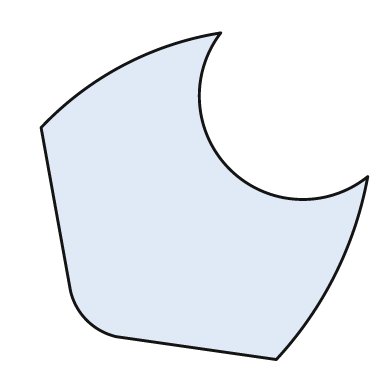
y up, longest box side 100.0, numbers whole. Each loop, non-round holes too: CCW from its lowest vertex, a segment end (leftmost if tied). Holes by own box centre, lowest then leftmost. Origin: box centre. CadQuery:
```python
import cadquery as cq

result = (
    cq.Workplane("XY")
    .moveTo(22.0, -50.0)
    .threePointArc((40.0, -24.0), (50.0, 6.0))
    .threePointArc((8.0, 8.0), (5.0, 50.0))
    .threePointArc((-25.0, 40.0), (-50.0, 21.0))
    .lineTo(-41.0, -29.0)
    .threePointArc((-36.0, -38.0), (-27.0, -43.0))
    .close()
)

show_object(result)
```